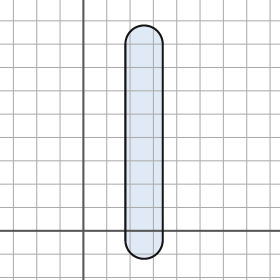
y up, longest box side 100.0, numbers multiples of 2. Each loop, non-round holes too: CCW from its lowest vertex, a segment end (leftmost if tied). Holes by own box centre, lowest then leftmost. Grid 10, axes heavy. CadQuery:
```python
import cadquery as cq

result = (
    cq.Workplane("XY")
    .moveTo(18.0, -4.0)
    .threePointArc((26.0, -12.0), (34.0, -4.0))
    .lineTo(34.0, 80.0)
    .threePointArc((26.0, 88.0), (18.0, 80.0))
    .close()
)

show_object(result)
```